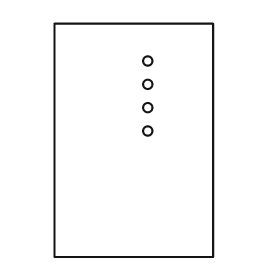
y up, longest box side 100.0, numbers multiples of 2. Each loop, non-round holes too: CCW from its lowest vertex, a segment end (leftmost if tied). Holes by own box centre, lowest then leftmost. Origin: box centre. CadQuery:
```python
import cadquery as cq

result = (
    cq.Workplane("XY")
    .moveTo(-34.0, -50.0)
    .lineTo(34.0, -50.0)
    .lineTo(34.0, 50.0)
    .lineTo(-34.0, 50.0)
    .close()
    .moveTo(6.0, 4.0)
    .circle(2.0)
    .moveTo(6.0, 14.0)
    .circle(2.0)
    .moveTo(6.0, 24.0)
    .circle(2.0)
    .moveTo(6.0, 34.0)
    .circle(2.0)
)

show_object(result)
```